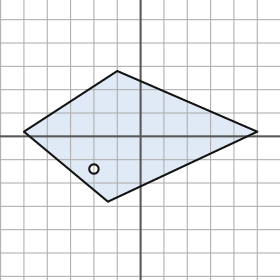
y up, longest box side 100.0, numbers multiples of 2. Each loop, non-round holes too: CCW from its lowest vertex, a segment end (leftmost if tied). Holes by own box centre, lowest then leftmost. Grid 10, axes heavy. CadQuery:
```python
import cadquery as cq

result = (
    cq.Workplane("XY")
    .moveTo(-14.0, -28.0)
    .lineTo(50.0, 2.0)
    .lineTo(-10.0, 28.0)
    .lineTo(-50.0, 2.0)
    .close()
    .moveTo(-20.0, -14.0)
    .circle(2.0)
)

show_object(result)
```